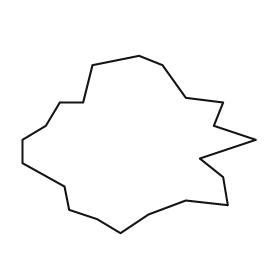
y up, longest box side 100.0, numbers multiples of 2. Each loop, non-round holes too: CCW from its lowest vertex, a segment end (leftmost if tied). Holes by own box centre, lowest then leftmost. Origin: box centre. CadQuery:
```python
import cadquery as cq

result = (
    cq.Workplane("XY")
    .moveTo(-8.0, -38.0)
    .lineTo(4.0, -30.0)
    .lineTo(20.0, -24.0)
    .lineTo(38.0, -26.0)
    .lineTo(36.0, -14.0)
    .lineTo(26.0, -6.0)
    .lineTo(50.0, 2.0)
    .lineTo(32.0, 8.0)
    .lineTo(36.0, 18.0)
    .lineTo(20.0, 20.0)
    .lineTo(10.0, 34.0)
    .lineTo(0.0, 38.0)
    .lineTo(-20.0, 34.0)
    .lineTo(-24.0, 18.0)
    .lineTo(-34.0, 18.0)
    .lineTo(-40.0, 8.0)
    .lineTo(-50.0, 2.0)
    .lineTo(-50.0, -8.0)
    .lineTo(-32.0, -18.0)
    .lineTo(-30.0, -28.0)
    .lineTo(-18.0, -32.0)
    .close()
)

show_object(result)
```